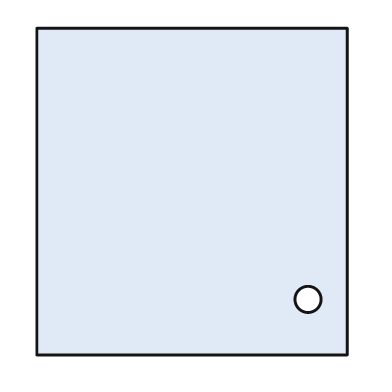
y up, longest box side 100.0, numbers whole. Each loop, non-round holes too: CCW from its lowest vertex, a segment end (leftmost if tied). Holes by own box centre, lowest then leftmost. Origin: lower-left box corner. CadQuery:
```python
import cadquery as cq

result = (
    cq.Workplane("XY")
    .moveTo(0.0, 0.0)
    .lineTo(95.0, 0.0)
    .lineTo(95.0, 100.0)
    .lineTo(0.0, 100.0)
    .close()
    .moveTo(83.0, 17.0)
    .circle(4.0)
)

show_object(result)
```